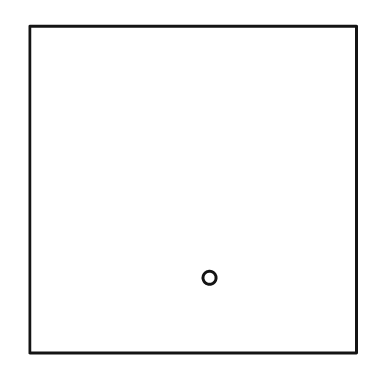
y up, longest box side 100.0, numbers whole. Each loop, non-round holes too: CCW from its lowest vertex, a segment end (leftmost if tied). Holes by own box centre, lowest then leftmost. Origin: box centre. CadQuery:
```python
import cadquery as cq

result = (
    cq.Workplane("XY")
    .moveTo(-50.0, -50.0)
    .lineTo(50.0, -50.0)
    .lineTo(50.0, 50.0)
    .lineTo(-50.0, 50.0)
    .close()
    .moveTo(5.0, -27.0)
    .circle(2.0)
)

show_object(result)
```